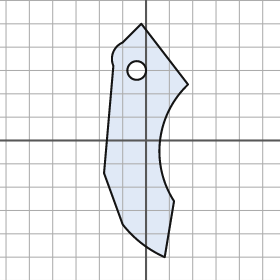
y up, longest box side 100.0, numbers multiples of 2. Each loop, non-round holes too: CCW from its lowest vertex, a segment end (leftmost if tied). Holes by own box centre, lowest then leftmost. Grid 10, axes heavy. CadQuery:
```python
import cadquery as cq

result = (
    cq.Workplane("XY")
    .moveTo(8.0, -50.0)
    .lineTo(12.0, -26.0)
    .threePointArc((6.0, 0.0), (18.0, 24.0))
    .lineTo(-2.0, 50.0)
    .lineTo(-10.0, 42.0)
    .threePointArc((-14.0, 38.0), (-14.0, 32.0))
    .lineTo(-18.0, -14.0)
    .lineTo(-10.0, -36.0)
    .threePointArc((-2.0, -44.0), (8.0, -50.0))
    .close()
    .moveTo(-4.0, 30.0)
    .circle(4.0)
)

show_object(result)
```